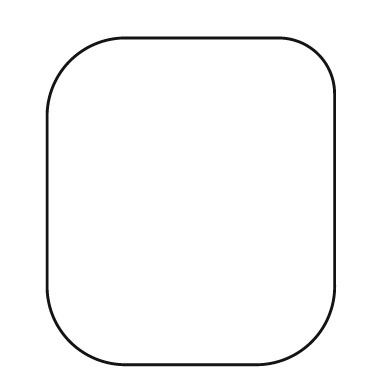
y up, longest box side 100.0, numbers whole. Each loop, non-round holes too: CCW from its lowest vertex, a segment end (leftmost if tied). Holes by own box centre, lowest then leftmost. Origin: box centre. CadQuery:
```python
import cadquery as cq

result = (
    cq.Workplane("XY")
    .moveTo(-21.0, -50.0)
    .lineTo(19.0, -50.0)
    .threePointArc((37.0, -43.0), (44.0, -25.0))
    .lineTo(44.0, 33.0)
    .threePointArc((39.0, 45.0), (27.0, 50.0))
    .lineTo(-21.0, 50.0)
    .threePointArc((-37.0, 43.0), (-44.0, 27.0))
    .lineTo(-44.0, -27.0)
    .threePointArc((-37.0, -43.0), (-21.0, -50.0))
    .close()
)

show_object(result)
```